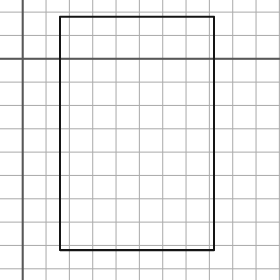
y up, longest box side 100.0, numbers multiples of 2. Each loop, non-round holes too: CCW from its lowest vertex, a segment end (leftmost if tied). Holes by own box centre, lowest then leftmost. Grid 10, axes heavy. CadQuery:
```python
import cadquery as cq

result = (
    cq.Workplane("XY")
    .moveTo(16.0, -82.0)
    .lineTo(82.0, -82.0)
    .lineTo(82.0, 18.0)
    .lineTo(16.0, 18.0)
    .close()
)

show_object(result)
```